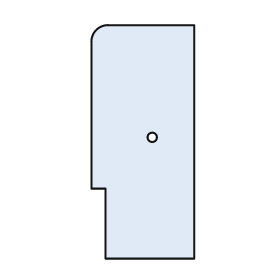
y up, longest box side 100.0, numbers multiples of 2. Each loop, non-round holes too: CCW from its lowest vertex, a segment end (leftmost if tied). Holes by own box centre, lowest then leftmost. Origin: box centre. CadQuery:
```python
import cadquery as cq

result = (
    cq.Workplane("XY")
    .moveTo(-16.0, -50.0)
    .lineTo(22.0, -50.0)
    .lineTo(22.0, 50.0)
    .lineTo(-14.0, 50.0)
    .threePointArc((-20.0, 48.0), (-22.0, 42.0))
    .lineTo(-22.0, -20.0)
    .lineTo(-16.0, -20.0)
    .close()
    .moveTo(4.0, 2.0)
    .circle(2.0)
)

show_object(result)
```